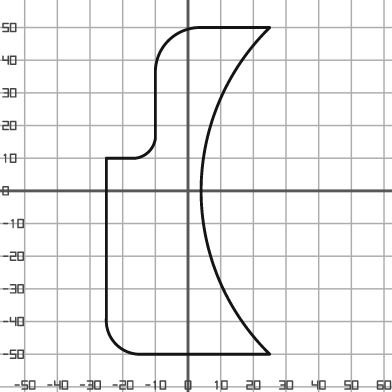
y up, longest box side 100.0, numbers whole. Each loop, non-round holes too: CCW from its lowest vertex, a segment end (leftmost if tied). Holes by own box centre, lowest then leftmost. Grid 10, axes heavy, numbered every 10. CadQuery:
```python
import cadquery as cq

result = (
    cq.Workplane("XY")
    .moveTo(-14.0, -50.0)
    .lineTo(25.0, -50.0)
    .threePointArc((4.0, 0.0), (25.0, 50.0))
    .lineTo(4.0, 50.0)
    .threePointArc((-6.0, 46.0), (-10.0, 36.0))
    .lineTo(-10.0, 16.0)
    .threePointArc((-12.0, 12.0), (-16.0, 10.0))
    .lineTo(-25.0, 10.0)
    .lineTo(-25.0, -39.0)
    .threePointArc((-22.0, -47.0), (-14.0, -50.0))
    .close()
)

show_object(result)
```